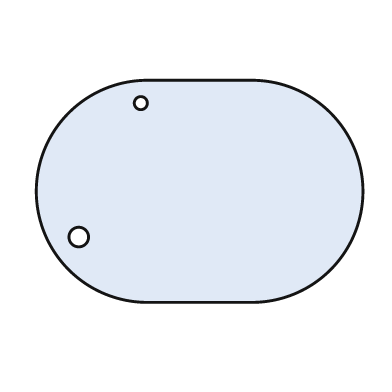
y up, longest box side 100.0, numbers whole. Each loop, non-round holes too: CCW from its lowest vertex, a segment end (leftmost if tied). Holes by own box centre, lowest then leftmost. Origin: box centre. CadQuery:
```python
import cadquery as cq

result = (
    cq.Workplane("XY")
    .moveTo(-16.0, -34.0)
    .lineTo(16.0, -34.0)
    .threePointArc((50.0, 0.0), (16.0, 34.0))
    .lineTo(-16.0, 34.0)
    .threePointArc((-50.0, 0.0), (-16.0, -34.0))
    .close()
    .moveTo(-37.0, -14.0)
    .circle(3.0)
    .moveTo(-18.0, 27.0)
    .circle(2.0)
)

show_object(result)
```